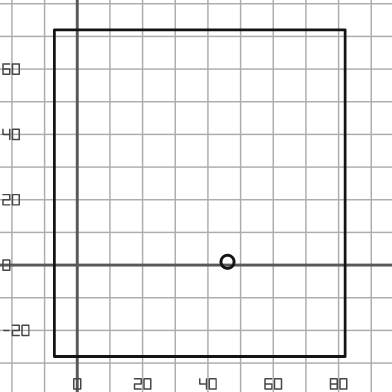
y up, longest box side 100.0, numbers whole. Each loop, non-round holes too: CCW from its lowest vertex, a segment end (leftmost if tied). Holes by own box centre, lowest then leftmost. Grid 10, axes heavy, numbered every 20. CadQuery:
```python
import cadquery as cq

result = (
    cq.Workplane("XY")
    .moveTo(-7.0, -28.0)
    .lineTo(82.0, -28.0)
    .lineTo(82.0, 72.0)
    .lineTo(-7.0, 72.0)
    .close()
    .moveTo(46.0, 1.0)
    .circle(2.0)
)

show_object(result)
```